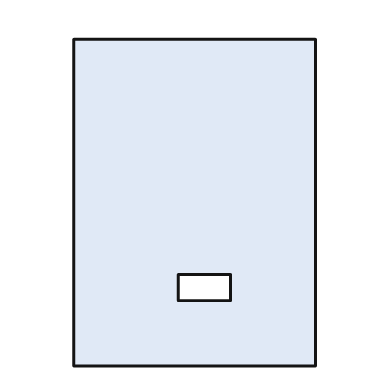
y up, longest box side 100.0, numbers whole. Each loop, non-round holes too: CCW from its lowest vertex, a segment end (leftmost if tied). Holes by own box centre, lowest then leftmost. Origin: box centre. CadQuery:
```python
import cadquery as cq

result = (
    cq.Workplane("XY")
    .moveTo(-37.0, -50.0)
    .lineTo(37.0, -50.0)
    .lineTo(37.0, 50.0)
    .lineTo(-37.0, 50.0)
    .close()
    .moveTo(-5.0, -30.0)
    .lineTo(11.0, -30.0)
    .lineTo(11.0, -22.0)
    .lineTo(-5.0, -22.0)
    .close()
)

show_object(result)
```